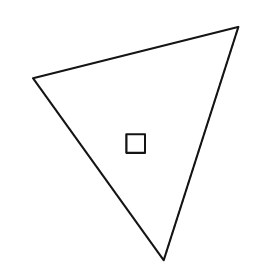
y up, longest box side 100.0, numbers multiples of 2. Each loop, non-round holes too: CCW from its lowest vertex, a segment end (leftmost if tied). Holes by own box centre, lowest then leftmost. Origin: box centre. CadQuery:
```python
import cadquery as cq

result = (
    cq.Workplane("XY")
    .moveTo(12.0, -50.0)
    .lineTo(44.0, 50.0)
    .lineTo(-44.0, 28.0)
    .close()
    .moveTo(-4.0, -4.0)
    .lineTo(4.0, -4.0)
    .lineTo(4.0, 4.0)
    .lineTo(-4.0, 4.0)
    .close()
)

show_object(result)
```